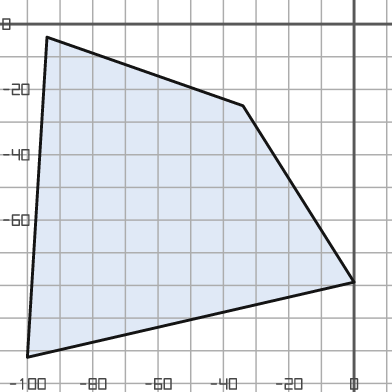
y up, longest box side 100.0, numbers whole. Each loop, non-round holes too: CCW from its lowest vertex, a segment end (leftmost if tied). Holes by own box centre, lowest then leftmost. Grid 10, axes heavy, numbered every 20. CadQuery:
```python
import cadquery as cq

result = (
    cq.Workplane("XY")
    .moveTo(-100.0, -102.0)
    .lineTo(0.0, -79.0)
    .lineTo(-34.0, -25.0)
    .lineTo(-94.0, -4.0)
    .close()
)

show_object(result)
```